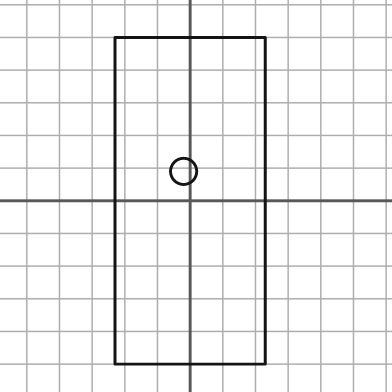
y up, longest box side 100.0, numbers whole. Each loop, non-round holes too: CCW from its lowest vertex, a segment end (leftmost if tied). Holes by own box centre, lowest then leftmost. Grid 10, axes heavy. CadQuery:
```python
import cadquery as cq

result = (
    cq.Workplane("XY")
    .moveTo(-23.0, -50.0)
    .lineTo(23.0, -50.0)
    .lineTo(23.0, 50.0)
    .lineTo(-23.0, 50.0)
    .close()
    .moveTo(-2.0, 9.0)
    .circle(4.0)
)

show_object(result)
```